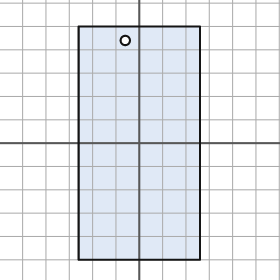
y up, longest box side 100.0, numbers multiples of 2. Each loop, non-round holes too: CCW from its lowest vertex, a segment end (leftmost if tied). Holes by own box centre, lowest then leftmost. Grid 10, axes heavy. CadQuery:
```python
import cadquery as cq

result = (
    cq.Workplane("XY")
    .moveTo(-26.0, -50.0)
    .lineTo(26.0, -50.0)
    .lineTo(26.0, 50.0)
    .lineTo(-26.0, 50.0)
    .close()
    .moveTo(-6.0, 44.0)
    .circle(2.0)
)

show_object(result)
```